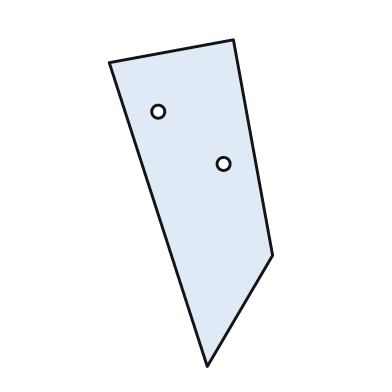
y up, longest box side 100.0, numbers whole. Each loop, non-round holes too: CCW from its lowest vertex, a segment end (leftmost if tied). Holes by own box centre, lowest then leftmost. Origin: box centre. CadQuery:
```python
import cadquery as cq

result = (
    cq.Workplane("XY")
    .moveTo(5.0, -50.0)
    .lineTo(25.0, -16.0)
    .lineTo(13.0, 50.0)
    .lineTo(-25.0, 43.0)
    .close()
    .moveTo(10.0, 12.0)
    .circle(2.0)
    .moveTo(-10.0, 28.0)
    .circle(2.0)
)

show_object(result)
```